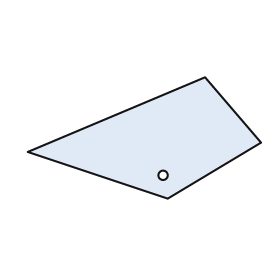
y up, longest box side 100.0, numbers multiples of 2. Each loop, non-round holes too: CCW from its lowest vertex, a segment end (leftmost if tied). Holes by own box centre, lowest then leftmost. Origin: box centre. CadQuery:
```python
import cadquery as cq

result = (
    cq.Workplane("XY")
    .moveTo(10.0, -26.0)
    .lineTo(50.0, -2.0)
    .lineTo(26.0, 26.0)
    .lineTo(-50.0, -6.0)
    .close()
    .moveTo(8.0, -16.0)
    .circle(2.0)
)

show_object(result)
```